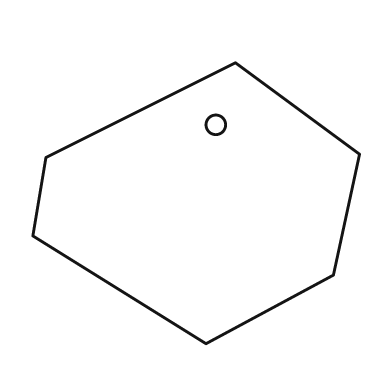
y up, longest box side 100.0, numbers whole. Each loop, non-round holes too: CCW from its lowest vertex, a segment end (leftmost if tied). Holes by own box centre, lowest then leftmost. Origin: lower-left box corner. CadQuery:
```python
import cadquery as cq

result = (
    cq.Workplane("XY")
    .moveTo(53.0, 0.0)
    .lineTo(92.0, 21.0)
    .lineTo(100.0, 58.0)
    .lineTo(62.0, 86.0)
    .lineTo(4.0, 57.0)
    .lineTo(0.0, 33.0)
    .close()
    .moveTo(56.0, 67.0)
    .circle(3.0)
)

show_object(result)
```